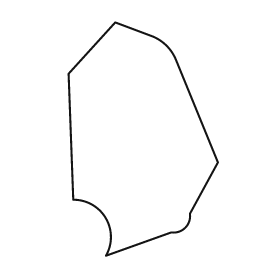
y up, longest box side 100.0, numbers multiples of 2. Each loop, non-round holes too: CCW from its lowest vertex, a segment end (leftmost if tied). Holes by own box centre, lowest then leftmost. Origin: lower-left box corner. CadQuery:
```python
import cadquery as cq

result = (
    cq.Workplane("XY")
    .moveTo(16.0, 0.0)
    .lineTo(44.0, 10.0)
    .threePointArc((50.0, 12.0), (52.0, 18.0))
    .lineTo(64.0, 40.0)
    .lineTo(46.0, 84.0)
    .threePointArc((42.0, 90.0), (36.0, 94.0))
    .lineTo(20.0, 100.0)
    .lineTo(0.0, 78.0)
    .lineTo(2.0, 24.0)
    .threePointArc((16.0, 16.0), (16.0, 0.0))
    .close()
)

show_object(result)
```